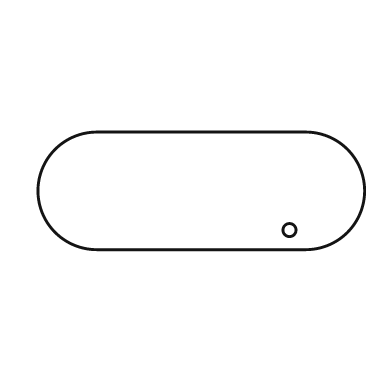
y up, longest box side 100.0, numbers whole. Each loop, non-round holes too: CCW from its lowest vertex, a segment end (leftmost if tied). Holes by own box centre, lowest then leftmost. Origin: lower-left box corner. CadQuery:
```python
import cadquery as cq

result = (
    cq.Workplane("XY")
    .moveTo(18.0, 0.0)
    .lineTo(82.0, 0.0)
    .threePointArc((100.0, 18.0), (82.0, 36.0))
    .lineTo(18.0, 36.0)
    .threePointArc((0.0, 18.0), (18.0, 0.0))
    .close()
    .moveTo(77.0, 6.0)
    .circle(2.0)
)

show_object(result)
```